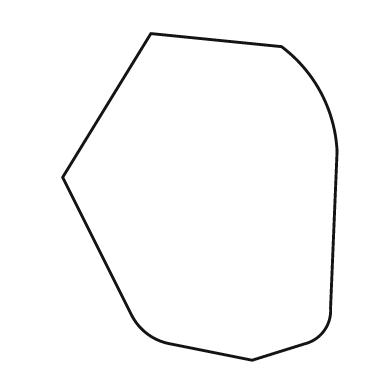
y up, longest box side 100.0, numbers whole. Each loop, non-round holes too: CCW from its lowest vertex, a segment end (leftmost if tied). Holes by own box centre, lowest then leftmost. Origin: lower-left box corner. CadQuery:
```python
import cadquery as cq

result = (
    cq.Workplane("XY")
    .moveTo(58.0, 0.0)
    .lineTo(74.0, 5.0)
    .threePointArc((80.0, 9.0), (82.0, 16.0))
    .lineTo(84.0, 64.0)
    .threePointArc((79.0, 82.0), (67.0, 96.0))
    .lineTo(27.0, 100.0)
    .lineTo(0.0, 56.0)
    .lineTo(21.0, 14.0)
    .threePointArc((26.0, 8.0), (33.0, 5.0))
    .close()
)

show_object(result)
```